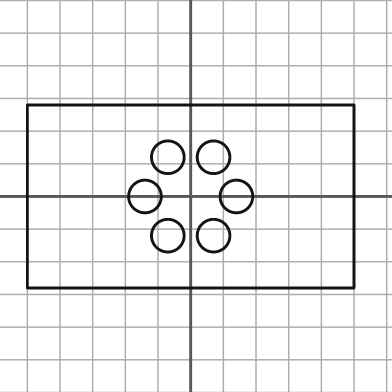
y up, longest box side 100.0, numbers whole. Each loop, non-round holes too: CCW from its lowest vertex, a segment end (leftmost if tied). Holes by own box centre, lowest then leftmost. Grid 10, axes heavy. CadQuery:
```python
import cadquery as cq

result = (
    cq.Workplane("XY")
    .moveTo(-50.0, -28.0)
    .lineTo(50.0, -28.0)
    .lineTo(50.0, 28.0)
    .lineTo(-50.0, 28.0)
    .close()
    .moveTo(-7.0, -12.0)
    .circle(5.0)
    .moveTo(7.0, -12.0)
    .circle(5.0)
    .moveTo(-14.0, 0.0)
    .circle(5.0)
    .moveTo(14.0, 0.0)
    .circle(5.0)
    .moveTo(-7.0, 12.0)
    .circle(5.0)
    .moveTo(7.0, 12.0)
    .circle(5.0)
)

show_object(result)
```